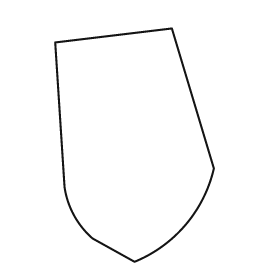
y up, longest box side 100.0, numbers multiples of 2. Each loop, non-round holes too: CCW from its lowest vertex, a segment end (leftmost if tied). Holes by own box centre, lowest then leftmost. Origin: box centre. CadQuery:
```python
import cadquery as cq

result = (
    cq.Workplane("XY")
    .moveTo(0.0, -50.0)
    .threePointArc((22.0, -34.0), (34.0, -10.0))
    .lineTo(16.0, 50.0)
    .lineTo(-34.0, 44.0)
    .lineTo(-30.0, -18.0)
    .threePointArc((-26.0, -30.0), (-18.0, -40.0))
    .close()
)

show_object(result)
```